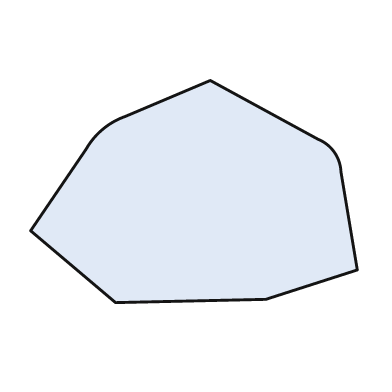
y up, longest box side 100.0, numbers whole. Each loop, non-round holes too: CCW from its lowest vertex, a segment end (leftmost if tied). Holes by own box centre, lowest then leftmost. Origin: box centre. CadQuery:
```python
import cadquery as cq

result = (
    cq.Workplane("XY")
    .moveTo(-24.0, -34.0)
    .lineTo(22.0, -33.0)
    .lineTo(50.0, -24.0)
    .lineTo(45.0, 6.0)
    .threePointArc((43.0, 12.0), (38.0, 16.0))
    .lineTo(5.0, 34.0)
    .lineTo(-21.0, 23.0)
    .threePointArc((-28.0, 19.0), (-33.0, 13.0))
    .lineTo(-50.0, -12.0)
    .close()
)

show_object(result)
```